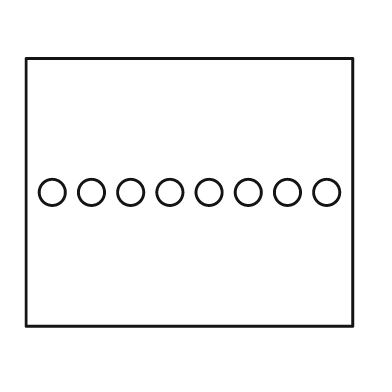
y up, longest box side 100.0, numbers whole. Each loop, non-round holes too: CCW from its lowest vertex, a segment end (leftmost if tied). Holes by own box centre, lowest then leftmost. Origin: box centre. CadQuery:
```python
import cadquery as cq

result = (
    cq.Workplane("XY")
    .moveTo(-50.0, -41.0)
    .lineTo(50.0, -41.0)
    .lineTo(50.0, 41.0)
    .lineTo(-50.0, 41.0)
    .close()
    .moveTo(-42.0, 0.0)
    .circle(4.0)
    .moveTo(-30.0, 0.0)
    .circle(4.0)
    .moveTo(-18.0, 0.0)
    .circle(4.0)
    .moveTo(-6.0, 0.0)
    .circle(4.0)
    .moveTo(6.0, 0.0)
    .circle(4.0)
    .moveTo(18.0, 0.0)
    .circle(4.0)
    .moveTo(30.0, 0.0)
    .circle(4.0)
    .moveTo(42.0, 0.0)
    .circle(4.0)
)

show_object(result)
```